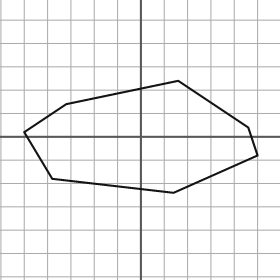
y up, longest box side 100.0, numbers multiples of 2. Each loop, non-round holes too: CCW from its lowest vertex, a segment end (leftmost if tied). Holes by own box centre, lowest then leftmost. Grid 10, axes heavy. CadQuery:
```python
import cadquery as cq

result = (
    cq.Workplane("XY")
    .moveTo(14.0, -24.0)
    .lineTo(50.0, -8.0)
    .lineTo(46.0, 4.0)
    .lineTo(16.0, 24.0)
    .lineTo(-32.0, 14.0)
    .lineTo(-50.0, 2.0)
    .lineTo(-38.0, -18.0)
    .close()
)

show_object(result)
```